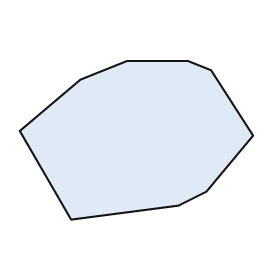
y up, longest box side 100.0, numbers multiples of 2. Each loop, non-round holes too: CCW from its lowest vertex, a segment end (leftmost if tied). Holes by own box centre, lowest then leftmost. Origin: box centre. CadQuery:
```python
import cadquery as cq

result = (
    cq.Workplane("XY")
    .moveTo(-28.0, -34.0)
    .lineTo(18.0, -28.0)
    .lineTo(30.0, -22.0)
    .lineTo(50.0, 2.0)
    .lineTo(32.0, 30.0)
    .lineTo(22.0, 34.0)
    .lineTo(-4.0, 34.0)
    .lineTo(-24.0, 26.0)
    .lineTo(-50.0, 4.0)
    .close()
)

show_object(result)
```